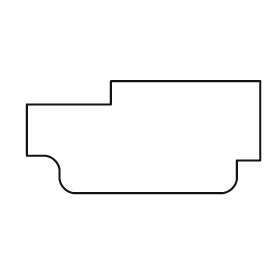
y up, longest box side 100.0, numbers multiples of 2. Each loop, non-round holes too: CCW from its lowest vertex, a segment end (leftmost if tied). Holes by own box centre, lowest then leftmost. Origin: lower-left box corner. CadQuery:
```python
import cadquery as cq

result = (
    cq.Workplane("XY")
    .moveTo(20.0, 0.0)
    .lineTo(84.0, 0.0)
    .threePointArc((88.0, 2.0), (90.0, 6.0))
    .lineTo(90.0, 14.0)
    .lineTo(100.0, 14.0)
    .lineTo(100.0, 48.0)
    .lineTo(36.0, 48.0)
    .lineTo(36.0, 38.0)
    .lineTo(0.0, 38.0)
    .lineTo(0.0, 16.0)
    .lineTo(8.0, 16.0)
    .threePointArc((12.0, 14.0), (14.0, 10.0))
    .lineTo(14.0, 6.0)
    .threePointArc((16.0, 2.0), (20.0, 0.0))
    .close()
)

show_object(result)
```